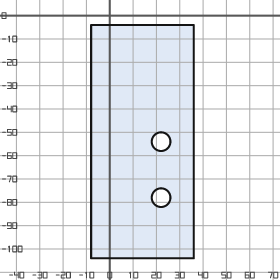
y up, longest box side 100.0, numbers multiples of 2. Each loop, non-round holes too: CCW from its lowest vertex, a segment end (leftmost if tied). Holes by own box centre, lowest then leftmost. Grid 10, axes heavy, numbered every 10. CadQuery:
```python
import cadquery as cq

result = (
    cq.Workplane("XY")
    .moveTo(-8.0, -104.0)
    .lineTo(36.0, -104.0)
    .lineTo(36.0, -4.0)
    .lineTo(-8.0, -4.0)
    .close()
    .moveTo(22.0, -78.0)
    .circle(4.0)
    .moveTo(22.0, -54.0)
    .circle(4.0)
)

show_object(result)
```